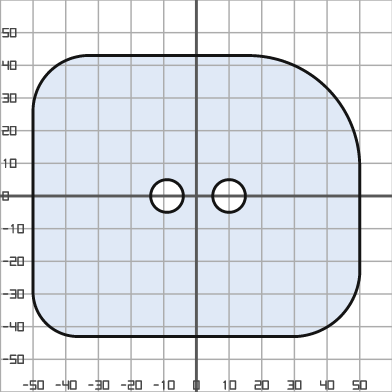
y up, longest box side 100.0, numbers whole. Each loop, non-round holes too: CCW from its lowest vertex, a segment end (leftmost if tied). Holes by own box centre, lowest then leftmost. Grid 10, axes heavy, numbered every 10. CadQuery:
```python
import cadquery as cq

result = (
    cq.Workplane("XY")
    .moveTo(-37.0, -43.0)
    .lineTo(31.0, -43.0)
    .threePointArc((44.0, -37.0), (50.0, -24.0))
    .lineTo(50.0, 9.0)
    .threePointArc((40.0, 33.0), (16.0, 43.0))
    .lineTo(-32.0, 43.0)
    .threePointArc((-45.0, 38.0), (-50.0, 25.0))
    .lineTo(-50.0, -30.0)
    .threePointArc((-46.0, -39.0), (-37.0, -43.0))
    .close()
    .moveTo(-9.0, 0.0)
    .circle(5.0)
    .moveTo(10.0, 0.0)
    .circle(5.0)
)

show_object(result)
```